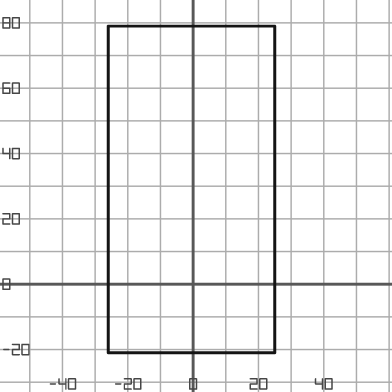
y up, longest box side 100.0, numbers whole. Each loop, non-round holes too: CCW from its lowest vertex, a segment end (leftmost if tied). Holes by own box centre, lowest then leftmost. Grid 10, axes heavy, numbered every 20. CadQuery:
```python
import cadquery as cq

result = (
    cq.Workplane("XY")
    .moveTo(-26.0, -21.0)
    .lineTo(25.0, -21.0)
    .lineTo(25.0, 79.0)
    .lineTo(-26.0, 79.0)
    .close()
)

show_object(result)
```